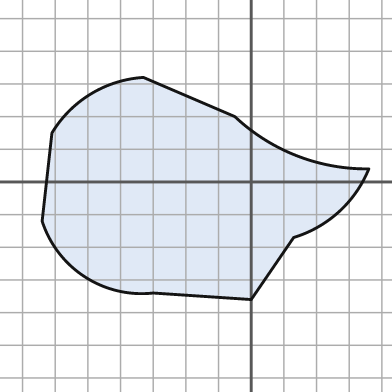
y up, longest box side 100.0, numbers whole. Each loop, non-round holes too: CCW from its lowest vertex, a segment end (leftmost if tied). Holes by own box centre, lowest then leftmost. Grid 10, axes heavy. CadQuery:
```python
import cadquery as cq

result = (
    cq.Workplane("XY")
    .moveTo(0.0, -36.0)
    .lineTo(13.0, -17.0)
    .threePointArc((27.0, -9.0), (36.0, 4.0))
    .threePointArc((14.0, 8.0), (-5.0, 20.0))
    .lineTo(-33.0, 32.0)
    .threePointArc((-49.0, 27.0), (-61.0, 15.0))
    .lineTo(-64.0, -12.0)
    .threePointArc((-51.0, -29.0), (-30.0, -34.0))
    .close()
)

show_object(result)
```